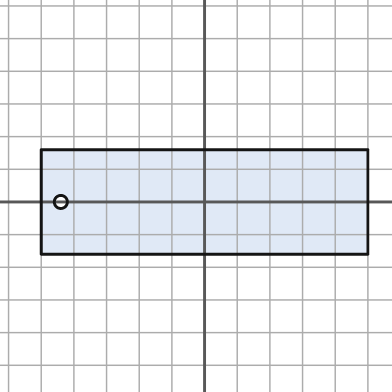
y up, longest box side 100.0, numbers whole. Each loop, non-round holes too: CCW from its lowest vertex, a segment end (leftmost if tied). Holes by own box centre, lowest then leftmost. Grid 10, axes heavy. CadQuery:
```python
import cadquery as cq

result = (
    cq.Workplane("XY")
    .moveTo(-50.0, -16.0)
    .lineTo(50.0, -16.0)
    .lineTo(50.0, 16.0)
    .lineTo(-50.0, 16.0)
    .close()
    .moveTo(-44.0, 0.0)
    .circle(2.0)
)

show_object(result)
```